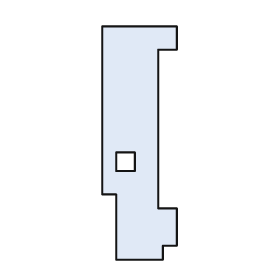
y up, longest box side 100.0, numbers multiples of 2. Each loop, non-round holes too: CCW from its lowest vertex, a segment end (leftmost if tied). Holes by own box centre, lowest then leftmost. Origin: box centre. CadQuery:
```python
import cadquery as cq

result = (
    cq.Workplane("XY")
    .moveTo(-10.0, -50.0)
    .lineTo(10.0, -50.0)
    .lineTo(10.0, -44.0)
    .lineTo(16.0, -44.0)
    .lineTo(16.0, -28.0)
    .lineTo(8.0, -28.0)
    .lineTo(8.0, 40.0)
    .lineTo(16.0, 40.0)
    .lineTo(16.0, 50.0)
    .lineTo(-16.0, 50.0)
    .lineTo(-16.0, -22.0)
    .lineTo(-10.0, -22.0)
    .close()
    .moveTo(-10.0, -12.0)
    .lineTo(-2.0, -12.0)
    .lineTo(-2.0, -4.0)
    .lineTo(-10.0, -4.0)
    .close()
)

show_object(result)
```